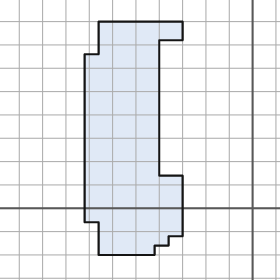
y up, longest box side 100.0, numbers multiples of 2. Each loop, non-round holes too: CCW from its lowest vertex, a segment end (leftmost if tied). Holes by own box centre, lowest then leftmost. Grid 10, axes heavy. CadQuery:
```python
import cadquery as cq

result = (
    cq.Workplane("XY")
    .moveTo(-66.0, -20.0)
    .lineTo(-42.0, -20.0)
    .lineTo(-42.0, -16.0)
    .lineTo(-36.0, -16.0)
    .lineTo(-36.0, -12.0)
    .lineTo(-30.0, -12.0)
    .lineTo(-30.0, 14.0)
    .lineTo(-40.0, 14.0)
    .lineTo(-40.0, 72.0)
    .lineTo(-30.0, 72.0)
    .lineTo(-30.0, 80.0)
    .lineTo(-66.0, 80.0)
    .lineTo(-66.0, 66.0)
    .lineTo(-72.0, 66.0)
    .lineTo(-72.0, -6.0)
    .lineTo(-66.0, -6.0)
    .close()
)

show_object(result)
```